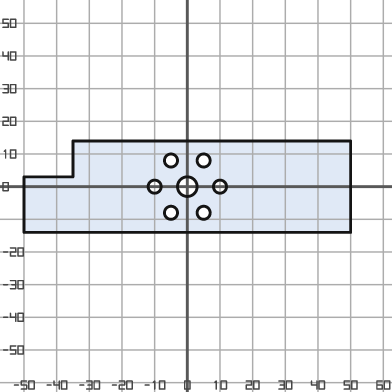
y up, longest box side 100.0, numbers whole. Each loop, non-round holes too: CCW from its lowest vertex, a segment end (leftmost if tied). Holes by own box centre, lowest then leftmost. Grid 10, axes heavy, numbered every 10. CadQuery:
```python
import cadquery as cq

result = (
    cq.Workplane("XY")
    .moveTo(-50.0, -14.0)
    .lineTo(50.0, -14.0)
    .lineTo(50.0, 14.0)
    .lineTo(-35.0, 14.0)
    .lineTo(-35.0, 3.0)
    .lineTo(-50.0, 3.0)
    .close()
    .moveTo(-5.0, -8.0)
    .circle(2.0)
    .moveTo(5.0, -8.0)
    .circle(2.0)
    .moveTo(-10.0, 0.0)
    .circle(2.0)
    .moveTo(0.0, 0.0)
    .circle(3.0)
    .moveTo(10.0, 0.0)
    .circle(2.0)
    .moveTo(-5.0, 8.0)
    .circle(2.0)
    .moveTo(5.0, 8.0)
    .circle(2.0)
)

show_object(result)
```